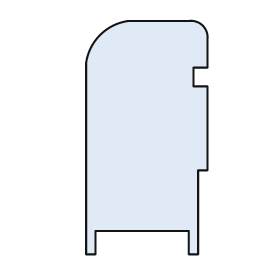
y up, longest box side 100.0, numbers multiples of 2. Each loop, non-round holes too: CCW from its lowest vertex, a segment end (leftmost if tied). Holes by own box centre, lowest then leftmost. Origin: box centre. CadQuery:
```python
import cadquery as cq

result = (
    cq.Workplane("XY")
    .moveTo(-26.0, -50.0)
    .lineTo(-22.0, -50.0)
    .lineTo(-22.0, -40.0)
    .lineTo(18.0, -40.0)
    .lineTo(18.0, -50.0)
    .lineTo(22.0, -50.0)
    .lineTo(22.0, -14.0)
    .lineTo(26.0, -14.0)
    .lineTo(26.0, 22.0)
    .lineTo(20.0, 22.0)
    .lineTo(20.0, 30.0)
    .lineTo(26.0, 30.0)
    .lineTo(26.0, 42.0)
    .threePointArc((24.0, 48.0), (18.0, 50.0))
    .lineTo(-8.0, 50.0)
    .threePointArc((-20.0, 44.0), (-26.0, 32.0))
    .close()
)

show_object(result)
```